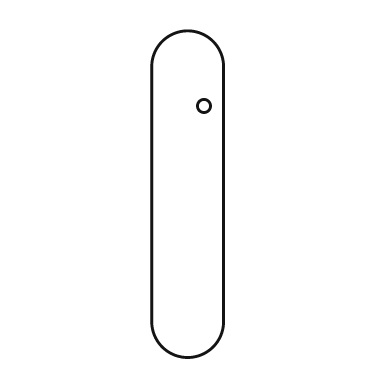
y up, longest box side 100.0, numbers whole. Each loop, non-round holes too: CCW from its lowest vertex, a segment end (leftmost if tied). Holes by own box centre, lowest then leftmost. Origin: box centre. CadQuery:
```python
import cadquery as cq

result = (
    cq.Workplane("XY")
    .moveTo(-11.0, -39.0)
    .threePointArc((0.0, -50.0), (11.0, -39.0))
    .lineTo(11.0, 39.0)
    .threePointArc((0.0, 50.0), (-11.0, 39.0))
    .close()
    .moveTo(5.0, 27.0)
    .circle(2.0)
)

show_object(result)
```